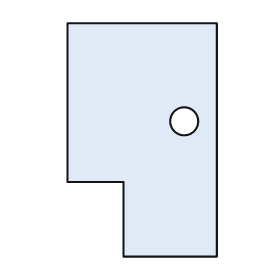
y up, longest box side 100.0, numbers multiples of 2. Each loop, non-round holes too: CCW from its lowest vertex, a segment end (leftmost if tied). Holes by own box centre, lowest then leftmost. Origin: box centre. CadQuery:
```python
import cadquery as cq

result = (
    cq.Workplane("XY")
    .moveTo(-8.0, -50.0)
    .lineTo(32.0, -50.0)
    .lineTo(32.0, 50.0)
    .lineTo(-32.0, 50.0)
    .lineTo(-32.0, -18.0)
    .lineTo(-8.0, -18.0)
    .close()
    .moveTo(18.0, 8.0)
    .circle(6.0)
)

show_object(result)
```